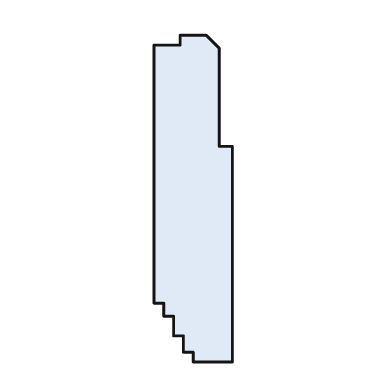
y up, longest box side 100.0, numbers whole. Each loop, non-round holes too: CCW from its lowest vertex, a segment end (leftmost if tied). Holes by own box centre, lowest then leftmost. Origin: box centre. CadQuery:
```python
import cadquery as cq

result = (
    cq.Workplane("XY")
    .moveTo(0.0, -50.0)
    .lineTo(12.0, -50.0)
    .lineTo(12.0, 16.0)
    .lineTo(8.0, 16.0)
    .lineTo(8.0, 46.0)
    .lineTo(4.0, 50.0)
    .lineTo(-4.0, 50.0)
    .lineTo(-4.0, 47.0)
    .lineTo(-12.0, 47.0)
    .lineTo(-12.0, -32.0)
    .lineTo(-9.0, -32.0)
    .lineTo(-9.0, -36.0)
    .lineTo(-6.0, -36.0)
    .lineTo(-6.0, -42.0)
    .lineTo(-3.0, -42.0)
    .lineTo(-3.0, -47.0)
    .lineTo(0.0, -47.0)
    .close()
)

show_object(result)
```